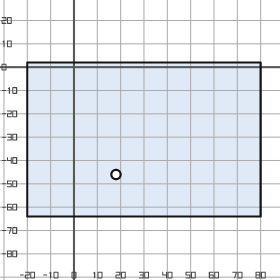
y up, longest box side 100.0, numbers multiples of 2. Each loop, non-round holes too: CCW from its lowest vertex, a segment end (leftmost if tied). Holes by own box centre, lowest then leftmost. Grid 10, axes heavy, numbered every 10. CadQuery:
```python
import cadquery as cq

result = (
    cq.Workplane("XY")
    .moveTo(-20.0, -64.0)
    .lineTo(80.0, -64.0)
    .lineTo(80.0, 2.0)
    .lineTo(-20.0, 2.0)
    .close()
    .moveTo(18.0, -46.0)
    .circle(2.0)
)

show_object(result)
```